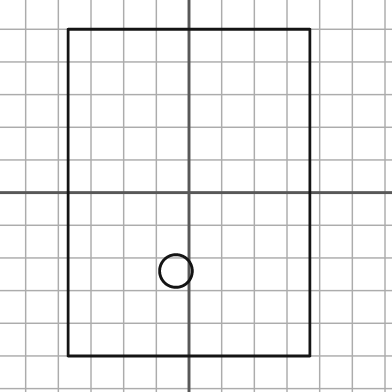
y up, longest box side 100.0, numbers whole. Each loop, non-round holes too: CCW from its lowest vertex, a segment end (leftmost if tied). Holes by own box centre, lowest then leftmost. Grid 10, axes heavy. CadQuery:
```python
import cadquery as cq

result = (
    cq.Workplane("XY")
    .moveTo(-37.0, -50.0)
    .lineTo(37.0, -50.0)
    .lineTo(37.0, 50.0)
    .lineTo(-37.0, 50.0)
    .close()
    .moveTo(-4.0, -24.0)
    .circle(5.0)
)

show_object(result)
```